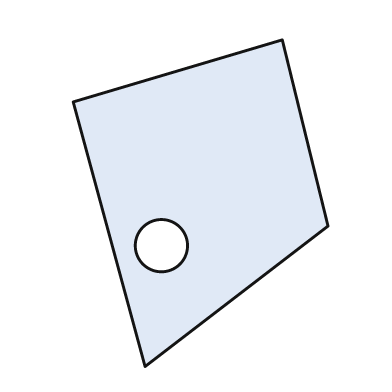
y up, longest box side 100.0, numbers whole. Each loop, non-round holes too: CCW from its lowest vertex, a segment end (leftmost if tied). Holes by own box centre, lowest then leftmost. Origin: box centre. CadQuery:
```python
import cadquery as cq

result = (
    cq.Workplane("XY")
    .moveTo(-17.0, -50.0)
    .lineTo(39.0, -7.0)
    .lineTo(25.0, 50.0)
    .lineTo(-39.0, 31.0)
    .close()
    .moveTo(-12.0, -13.0)
    .circle(8.0)
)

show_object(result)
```